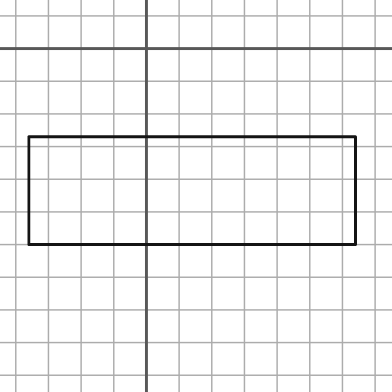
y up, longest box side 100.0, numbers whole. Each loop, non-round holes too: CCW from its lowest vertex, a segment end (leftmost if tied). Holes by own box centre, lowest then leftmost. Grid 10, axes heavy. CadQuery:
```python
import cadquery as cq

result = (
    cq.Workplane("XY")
    .moveTo(-36.0, -60.0)
    .lineTo(64.0, -60.0)
    .lineTo(64.0, -27.0)
    .lineTo(-36.0, -27.0)
    .close()
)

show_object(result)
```